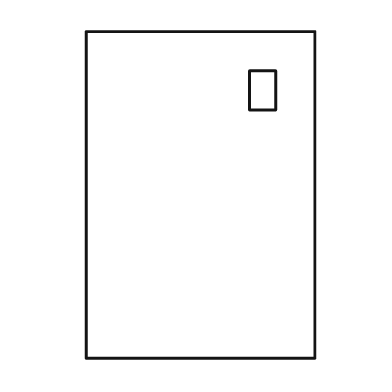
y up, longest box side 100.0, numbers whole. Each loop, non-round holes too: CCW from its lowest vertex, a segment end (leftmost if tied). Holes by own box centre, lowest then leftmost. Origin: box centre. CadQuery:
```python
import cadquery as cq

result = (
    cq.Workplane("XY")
    .moveTo(-35.0, -50.0)
    .lineTo(35.0, -50.0)
    .lineTo(35.0, 50.0)
    .lineTo(-35.0, 50.0)
    .close()
    .moveTo(15.0, 26.0)
    .lineTo(23.0, 26.0)
    .lineTo(23.0, 38.0)
    .lineTo(15.0, 38.0)
    .close()
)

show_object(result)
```